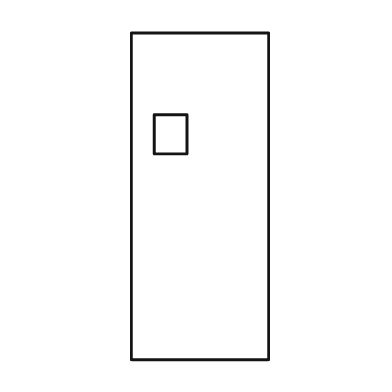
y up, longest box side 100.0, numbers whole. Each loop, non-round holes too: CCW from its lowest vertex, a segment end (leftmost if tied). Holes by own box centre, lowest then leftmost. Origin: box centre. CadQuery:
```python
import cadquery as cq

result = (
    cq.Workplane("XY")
    .moveTo(-21.0, -50.0)
    .lineTo(21.0, -50.0)
    .lineTo(21.0, 50.0)
    .lineTo(-21.0, 50.0)
    .close()
    .moveTo(-14.0, 13.0)
    .lineTo(-4.0, 13.0)
    .lineTo(-4.0, 25.0)
    .lineTo(-14.0, 25.0)
    .close()
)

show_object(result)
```